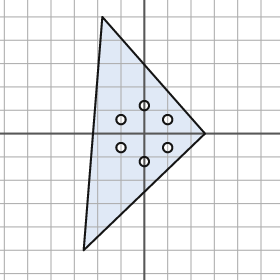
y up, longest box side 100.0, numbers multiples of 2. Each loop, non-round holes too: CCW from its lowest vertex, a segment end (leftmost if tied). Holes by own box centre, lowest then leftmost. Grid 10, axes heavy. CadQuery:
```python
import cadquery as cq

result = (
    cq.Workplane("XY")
    .moveTo(-26.0, -50.0)
    .lineTo(26.0, 0.0)
    .lineTo(-18.0, 50.0)
    .close()
    .moveTo(0.0, -12.0)
    .circle(2.0)
    .moveTo(-10.0, -6.0)
    .circle(2.0)
    .moveTo(10.0, -6.0)
    .circle(2.0)
    .moveTo(-10.0, 6.0)
    .circle(2.0)
    .moveTo(10.0, 6.0)
    .circle(2.0)
    .moveTo(0.0, 12.0)
    .circle(2.0)
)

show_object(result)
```